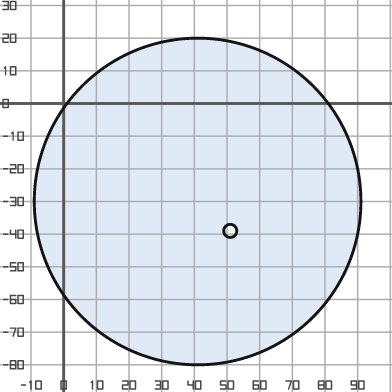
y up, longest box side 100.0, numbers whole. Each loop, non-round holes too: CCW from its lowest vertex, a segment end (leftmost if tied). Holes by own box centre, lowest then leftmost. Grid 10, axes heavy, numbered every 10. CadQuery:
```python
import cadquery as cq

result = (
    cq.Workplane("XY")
    .moveTo(41.0, -30.0)
    .circle(50.0)
    .moveTo(51.0, -39.0)
    .circle(2.0)
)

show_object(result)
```